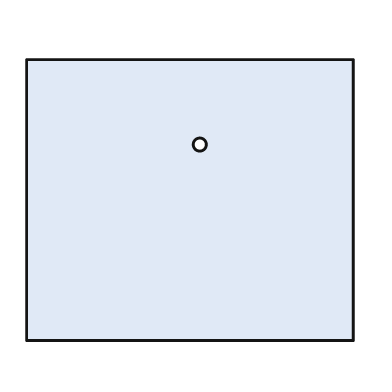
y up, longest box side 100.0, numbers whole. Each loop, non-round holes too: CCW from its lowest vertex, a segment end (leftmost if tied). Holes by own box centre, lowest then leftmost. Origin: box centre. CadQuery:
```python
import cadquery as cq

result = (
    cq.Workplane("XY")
    .moveTo(-50.0, -43.0)
    .lineTo(50.0, -43.0)
    .lineTo(50.0, 43.0)
    .lineTo(-50.0, 43.0)
    .close()
    .moveTo(3.0, 17.0)
    .circle(2.0)
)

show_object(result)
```